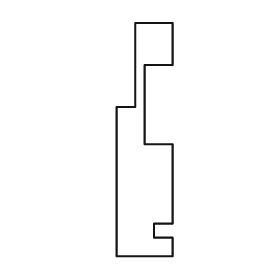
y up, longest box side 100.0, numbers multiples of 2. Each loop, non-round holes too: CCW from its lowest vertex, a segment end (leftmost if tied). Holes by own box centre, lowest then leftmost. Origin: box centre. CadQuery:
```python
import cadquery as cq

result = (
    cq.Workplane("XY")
    .moveTo(-12.0, -50.0)
    .lineTo(12.0, -50.0)
    .lineTo(12.0, -42.0)
    .lineTo(4.0, -42.0)
    .lineTo(4.0, -36.0)
    .lineTo(12.0, -36.0)
    .lineTo(12.0, -2.0)
    .lineTo(0.0, -2.0)
    .lineTo(0.0, 32.0)
    .lineTo(12.0, 32.0)
    .lineTo(12.0, 50.0)
    .lineTo(-4.0, 50.0)
    .lineTo(-4.0, 14.0)
    .lineTo(-12.0, 14.0)
    .close()
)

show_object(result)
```